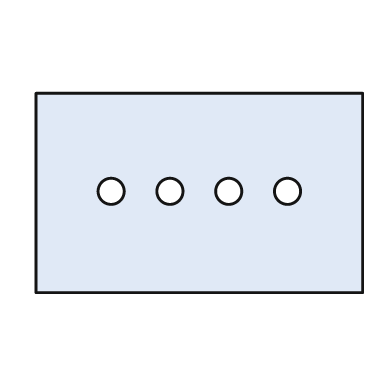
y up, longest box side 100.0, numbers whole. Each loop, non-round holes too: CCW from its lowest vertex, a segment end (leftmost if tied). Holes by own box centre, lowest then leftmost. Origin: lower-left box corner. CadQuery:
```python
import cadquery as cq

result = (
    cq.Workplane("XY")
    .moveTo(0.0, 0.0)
    .lineTo(100.0, 0.0)
    .lineTo(100.0, 61.0)
    .lineTo(0.0, 61.0)
    .close()
    .moveTo(23.0, 31.0)
    .circle(4.0)
    .moveTo(41.0, 31.0)
    .circle(4.0)
    .moveTo(59.0, 31.0)
    .circle(4.0)
    .moveTo(77.0, 31.0)
    .circle(4.0)
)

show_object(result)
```